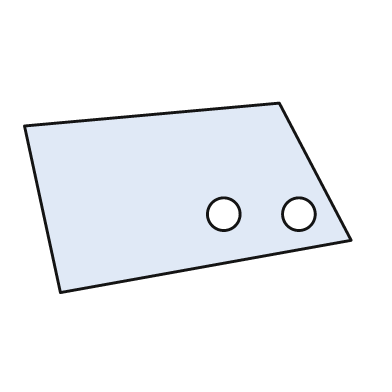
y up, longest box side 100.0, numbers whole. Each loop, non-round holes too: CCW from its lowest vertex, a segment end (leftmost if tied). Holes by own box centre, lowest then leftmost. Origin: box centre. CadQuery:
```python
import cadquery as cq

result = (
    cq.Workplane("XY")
    .moveTo(-39.0, -29.0)
    .lineTo(50.0, -13.0)
    .lineTo(28.0, 29.0)
    .lineTo(-50.0, 22.0)
    .close()
    .moveTo(11.0, -5.0)
    .circle(5.0)
    .moveTo(34.0, -5.0)
    .circle(5.0)
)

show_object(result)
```